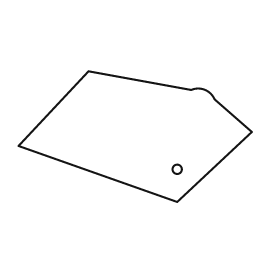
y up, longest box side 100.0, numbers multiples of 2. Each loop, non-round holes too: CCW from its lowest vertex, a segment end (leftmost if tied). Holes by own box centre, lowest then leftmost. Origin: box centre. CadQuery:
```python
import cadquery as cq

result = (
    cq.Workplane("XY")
    .moveTo(18.0, -28.0)
    .lineTo(50.0, 2.0)
    .lineTo(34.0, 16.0)
    .threePointArc((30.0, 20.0), (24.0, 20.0))
    .lineTo(-20.0, 28.0)
    .lineTo(-50.0, -4.0)
    .close()
    .moveTo(18.0, -14.0)
    .circle(2.0)
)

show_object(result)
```